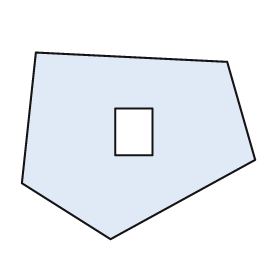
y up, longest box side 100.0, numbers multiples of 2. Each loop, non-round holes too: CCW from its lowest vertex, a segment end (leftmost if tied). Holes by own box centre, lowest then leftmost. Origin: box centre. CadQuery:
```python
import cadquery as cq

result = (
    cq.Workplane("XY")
    .moveTo(-12.0, -40.0)
    .lineTo(50.0, -6.0)
    .lineTo(38.0, 36.0)
    .lineTo(-44.0, 40.0)
    .lineTo(-50.0, -16.0)
    .close()
    .moveTo(-10.0, -4.0)
    .lineTo(6.0, -4.0)
    .lineTo(6.0, 16.0)
    .lineTo(-10.0, 16.0)
    .close()
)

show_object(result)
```